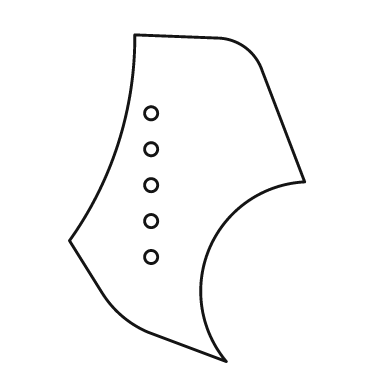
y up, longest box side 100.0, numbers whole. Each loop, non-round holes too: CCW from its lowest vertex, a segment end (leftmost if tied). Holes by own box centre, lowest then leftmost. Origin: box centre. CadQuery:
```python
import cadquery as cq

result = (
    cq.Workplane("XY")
    .moveTo(12.0, -50.0)
    .threePointArc((7.0, -15.0), (36.0, 5.0))
    .lineTo(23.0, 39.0)
    .threePointArc((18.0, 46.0), (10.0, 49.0))
    .lineTo(-16.0, 50.0)
    .threePointArc((-21.0, 17.0), (-36.0, -13.0))
    .lineTo(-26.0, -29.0)
    .threePointArc((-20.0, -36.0), (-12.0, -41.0))
    .close()
    .moveTo(-11.0, -18.0)
    .circle(2.0)
    .moveTo(-11.0, -7.0)
    .circle(2.0)
    .moveTo(-11.0, 4.0)
    .circle(2.0)
    .moveTo(-11.0, 15.0)
    .circle(2.0)
    .moveTo(-11.0, 26.0)
    .circle(2.0)
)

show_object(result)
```